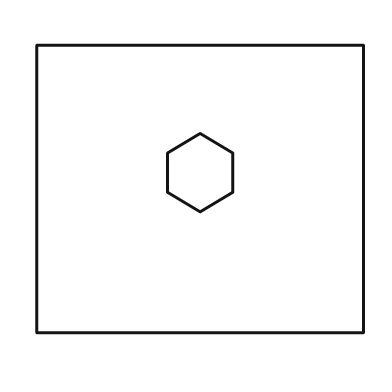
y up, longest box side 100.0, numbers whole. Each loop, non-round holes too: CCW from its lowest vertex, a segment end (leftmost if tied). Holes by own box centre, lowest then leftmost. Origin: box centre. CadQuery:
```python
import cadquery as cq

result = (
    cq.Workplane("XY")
    .moveTo(-50.0, -44.0)
    .lineTo(50.0, -44.0)
    .lineTo(50.0, 44.0)
    .lineTo(-50.0, 44.0)
    .close()
    .moveTo(0.0, -7.0)
    .lineTo(10.0, -1.0)
    .lineTo(10.0, 11.0)
    .lineTo(0.0, 17.0)
    .lineTo(-10.0, 11.0)
    .lineTo(-10.0, -1.0)
    .close()
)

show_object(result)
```